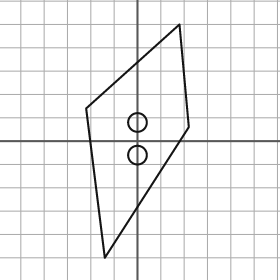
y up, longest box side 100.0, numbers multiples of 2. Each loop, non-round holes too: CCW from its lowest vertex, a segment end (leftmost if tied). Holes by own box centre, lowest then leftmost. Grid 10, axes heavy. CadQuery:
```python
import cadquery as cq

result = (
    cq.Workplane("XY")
    .moveTo(-14.0, -50.0)
    .lineTo(22.0, 6.0)
    .lineTo(18.0, 50.0)
    .lineTo(-22.0, 14.0)
    .close()
    .moveTo(0.0, -6.0)
    .circle(4.0)
    .moveTo(0.0, 8.0)
    .circle(4.0)
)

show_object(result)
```